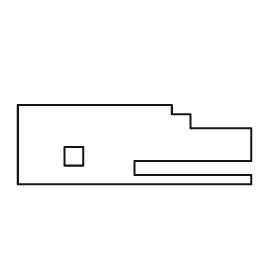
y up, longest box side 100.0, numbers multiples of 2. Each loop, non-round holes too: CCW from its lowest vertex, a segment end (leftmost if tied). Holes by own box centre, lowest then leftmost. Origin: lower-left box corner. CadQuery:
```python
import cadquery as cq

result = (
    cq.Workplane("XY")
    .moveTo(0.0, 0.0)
    .lineTo(100.0, 0.0)
    .lineTo(100.0, 4.0)
    .lineTo(50.0, 4.0)
    .lineTo(50.0, 10.0)
    .lineTo(100.0, 10.0)
    .lineTo(100.0, 24.0)
    .lineTo(74.0, 24.0)
    .lineTo(74.0, 30.0)
    .lineTo(66.0, 30.0)
    .lineTo(66.0, 34.0)
    .lineTo(0.0, 34.0)
    .close()
    .moveTo(20.0, 8.0)
    .lineTo(28.0, 8.0)
    .lineTo(28.0, 16.0)
    .lineTo(20.0, 16.0)
    .close()
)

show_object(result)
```